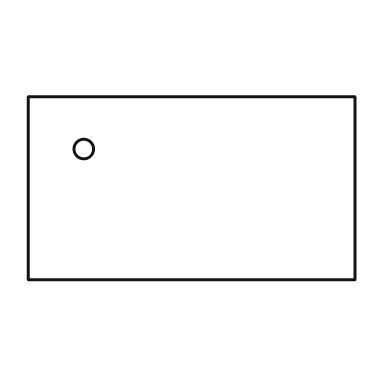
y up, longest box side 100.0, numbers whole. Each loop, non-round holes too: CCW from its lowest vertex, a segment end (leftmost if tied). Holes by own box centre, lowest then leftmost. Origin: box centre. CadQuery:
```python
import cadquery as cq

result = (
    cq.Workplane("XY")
    .moveTo(-50.0, -28.0)
    .lineTo(50.0, -28.0)
    .lineTo(50.0, 28.0)
    .lineTo(-50.0, 28.0)
    .close()
    .moveTo(-33.0, 12.0)
    .circle(3.0)
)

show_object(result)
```